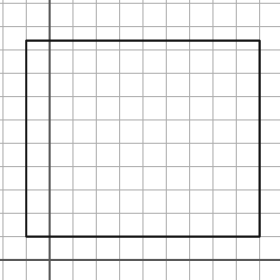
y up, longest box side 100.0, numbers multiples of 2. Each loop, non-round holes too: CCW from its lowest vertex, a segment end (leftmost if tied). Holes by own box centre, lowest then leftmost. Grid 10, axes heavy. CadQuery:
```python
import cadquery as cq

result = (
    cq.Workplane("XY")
    .moveTo(-10.0, 10.0)
    .lineTo(90.0, 10.0)
    .lineTo(90.0, 94.0)
    .lineTo(-10.0, 94.0)
    .close()
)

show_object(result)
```